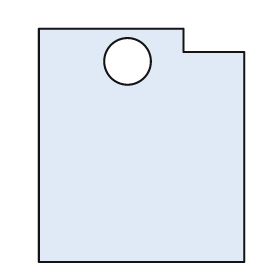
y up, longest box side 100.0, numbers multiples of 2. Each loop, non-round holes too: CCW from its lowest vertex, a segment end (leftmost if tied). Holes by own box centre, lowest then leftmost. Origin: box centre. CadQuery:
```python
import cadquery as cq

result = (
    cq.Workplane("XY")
    .moveTo(-44.0, -50.0)
    .lineTo(44.0, -50.0)
    .lineTo(44.0, 40.0)
    .lineTo(18.0, 40.0)
    .lineTo(18.0, 50.0)
    .lineTo(-44.0, 50.0)
    .close()
    .moveTo(-6.0, 36.0)
    .circle(10.0)
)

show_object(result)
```